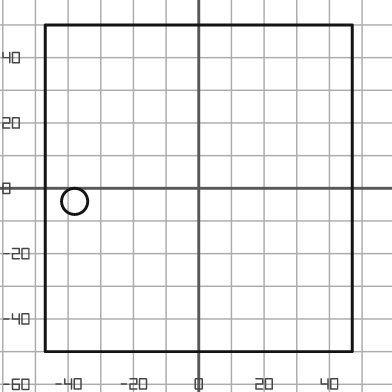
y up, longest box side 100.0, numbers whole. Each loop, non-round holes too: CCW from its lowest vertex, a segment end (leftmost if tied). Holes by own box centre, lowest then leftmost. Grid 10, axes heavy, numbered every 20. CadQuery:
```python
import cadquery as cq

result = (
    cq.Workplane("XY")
    .moveTo(-47.0, -50.0)
    .lineTo(47.0, -50.0)
    .lineTo(47.0, 50.0)
    .lineTo(-47.0, 50.0)
    .close()
    .moveTo(-38.0, -4.0)
    .circle(4.0)
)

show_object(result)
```